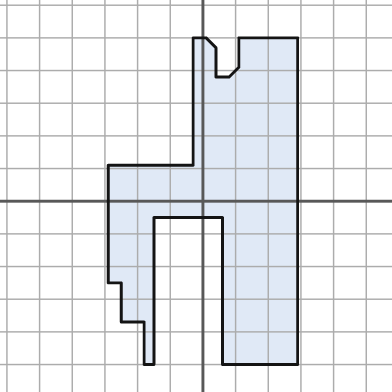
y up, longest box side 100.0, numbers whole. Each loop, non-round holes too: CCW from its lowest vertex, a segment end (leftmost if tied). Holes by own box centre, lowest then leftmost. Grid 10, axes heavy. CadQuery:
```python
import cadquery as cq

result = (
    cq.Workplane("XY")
    .moveTo(-18.0, -50.0)
    .lineTo(-15.0, -50.0)
    .lineTo(-15.0, -5.0)
    .lineTo(6.0, -5.0)
    .lineTo(6.0, -50.0)
    .lineTo(29.0, -50.0)
    .lineTo(29.0, 50.0)
    .lineTo(11.0, 50.0)
    .lineTo(11.0, 41.0)
    .lineTo(8.0, 38.0)
    .lineTo(4.0, 38.0)
    .lineTo(4.0, 47.0)
    .lineTo(1.0, 50.0)
    .lineTo(-3.0, 50.0)
    .lineTo(-3.0, 11.0)
    .lineTo(-29.0, 11.0)
    .lineTo(-29.0, -25.0)
    .lineTo(-25.0, -25.0)
    .lineTo(-25.0, -37.0)
    .lineTo(-18.0, -37.0)
    .close()
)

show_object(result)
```